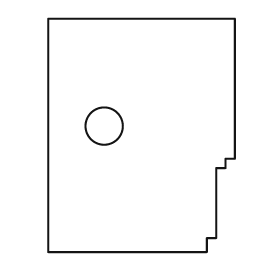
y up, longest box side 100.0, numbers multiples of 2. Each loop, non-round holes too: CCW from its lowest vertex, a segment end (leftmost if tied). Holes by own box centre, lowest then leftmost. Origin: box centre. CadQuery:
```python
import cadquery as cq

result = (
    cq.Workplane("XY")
    .moveTo(-40.0, -50.0)
    .lineTo(28.0, -50.0)
    .lineTo(28.0, -44.0)
    .lineTo(32.0, -44.0)
    .lineTo(32.0, -14.0)
    .lineTo(36.0, -14.0)
    .lineTo(36.0, -10.0)
    .lineTo(40.0, -10.0)
    .lineTo(40.0, 50.0)
    .lineTo(-40.0, 50.0)
    .close()
    .moveTo(-16.0, 4.0)
    .circle(8.0)
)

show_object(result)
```